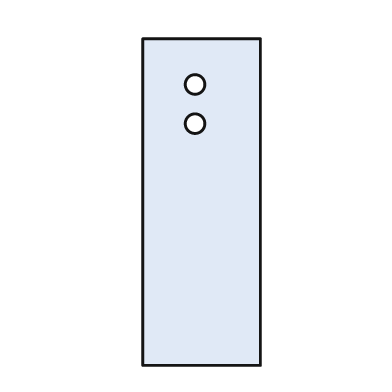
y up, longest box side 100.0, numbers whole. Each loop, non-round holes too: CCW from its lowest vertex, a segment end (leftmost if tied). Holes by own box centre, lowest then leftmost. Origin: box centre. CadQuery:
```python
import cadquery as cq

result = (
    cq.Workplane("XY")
    .moveTo(-18.0, -50.0)
    .lineTo(18.0, -50.0)
    .lineTo(18.0, 50.0)
    .lineTo(-18.0, 50.0)
    .close()
    .moveTo(-2.0, 24.0)
    .circle(3.0)
    .moveTo(-2.0, 36.0)
    .circle(3.0)
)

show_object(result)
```